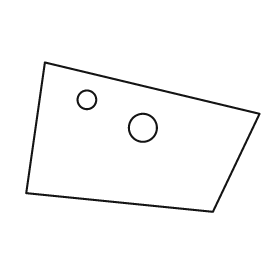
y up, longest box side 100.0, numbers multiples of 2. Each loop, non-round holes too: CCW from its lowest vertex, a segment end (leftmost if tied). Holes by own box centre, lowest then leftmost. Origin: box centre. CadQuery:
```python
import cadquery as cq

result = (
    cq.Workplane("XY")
    .moveTo(30.0, -32.0)
    .lineTo(50.0, 10.0)
    .lineTo(-42.0, 32.0)
    .lineTo(-50.0, -24.0)
    .close()
    .moveTo(0.0, 4.0)
    .circle(6.0)
    .moveTo(-24.0, 16.0)
    .circle(4.0)
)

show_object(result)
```